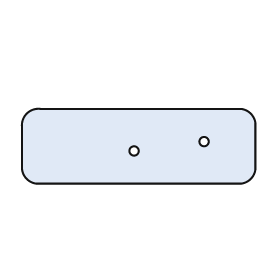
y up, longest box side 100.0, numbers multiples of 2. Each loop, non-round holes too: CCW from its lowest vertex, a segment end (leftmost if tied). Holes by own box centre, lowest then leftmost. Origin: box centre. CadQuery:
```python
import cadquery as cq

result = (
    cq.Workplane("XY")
    .moveTo(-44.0, -16.0)
    .lineTo(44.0, -16.0)
    .threePointArc((48.0, -14.0), (50.0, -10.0))
    .lineTo(50.0, 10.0)
    .threePointArc((48.0, 14.0), (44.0, 16.0))
    .lineTo(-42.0, 16.0)
    .threePointArc((-48.0, 14.0), (-50.0, 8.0))
    .lineTo(-50.0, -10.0)
    .threePointArc((-48.0, -14.0), (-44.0, -16.0))
    .close()
    .moveTo(-2.0, -2.0)
    .circle(2.0)
    .moveTo(28.0, 2.0)
    .circle(2.0)
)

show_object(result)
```